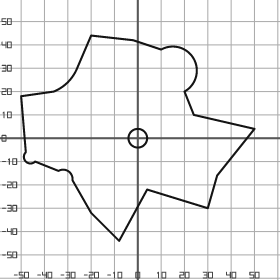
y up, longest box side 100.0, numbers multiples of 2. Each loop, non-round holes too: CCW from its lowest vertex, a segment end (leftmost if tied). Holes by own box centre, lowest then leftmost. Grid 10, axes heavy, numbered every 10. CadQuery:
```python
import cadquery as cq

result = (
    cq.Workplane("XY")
    .moveTo(-8.0, -44.0)
    .lineTo(4.0, -22.0)
    .lineTo(30.0, -30.0)
    .lineTo(34.0, -16.0)
    .lineTo(50.0, 4.0)
    .lineTo(24.0, 10.0)
    .lineTo(20.0, 20.0)
    .threePointArc((24.0, 34.0), (10.0, 38.0))
    .lineTo(-2.0, 42.0)
    .lineTo(-20.0, 44.0)
    .lineTo(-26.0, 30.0)
    .threePointArc((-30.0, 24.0), (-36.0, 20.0))
    .lineTo(-50.0, 18.0)
    .lineTo(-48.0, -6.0)
    .threePointArc((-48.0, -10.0), (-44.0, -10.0))
    .lineTo(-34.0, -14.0)
    .threePointArc((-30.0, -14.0), (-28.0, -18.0))
    .lineTo(-20.0, -32.0)
    .close()
    .moveTo(0.0, 0.0)
    .circle(4.0)
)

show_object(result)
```